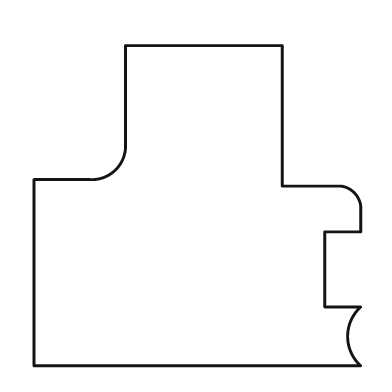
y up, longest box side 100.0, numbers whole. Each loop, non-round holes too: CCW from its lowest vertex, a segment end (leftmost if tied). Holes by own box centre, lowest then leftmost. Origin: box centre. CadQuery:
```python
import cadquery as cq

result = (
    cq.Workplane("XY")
    .moveTo(-50.0, -49.0)
    .lineTo(50.0, -49.0)
    .threePointArc((46.0, -40.0), (50.0, -31.0))
    .lineTo(39.0, -31.0)
    .lineTo(39.0, -8.0)
    .lineTo(50.0, -8.0)
    .lineTo(50.0, 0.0)
    .threePointArc((48.0, 4.0), (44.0, 6.0))
    .lineTo(26.0, 6.0)
    .lineTo(26.0, 49.0)
    .lineTo(-22.0, 49.0)
    .lineTo(-22.0, 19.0)
    .threePointArc((-25.0, 11.0), (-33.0, 8.0))
    .lineTo(-50.0, 8.0)
    .close()
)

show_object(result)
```